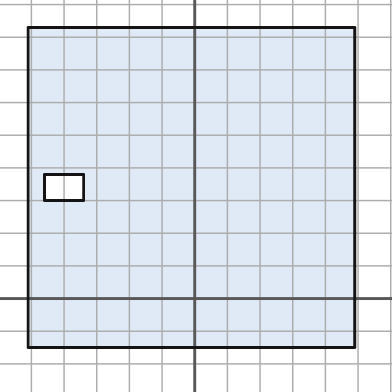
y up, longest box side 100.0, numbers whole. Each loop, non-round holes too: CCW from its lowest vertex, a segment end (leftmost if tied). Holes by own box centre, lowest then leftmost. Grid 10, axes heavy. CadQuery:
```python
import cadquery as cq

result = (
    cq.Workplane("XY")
    .moveTo(-51.0, -15.0)
    .lineTo(49.0, -15.0)
    .lineTo(49.0, 83.0)
    .lineTo(-51.0, 83.0)
    .close()
    .moveTo(-46.0, 30.0)
    .lineTo(-34.0, 30.0)
    .lineTo(-34.0, 38.0)
    .lineTo(-46.0, 38.0)
    .close()
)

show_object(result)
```